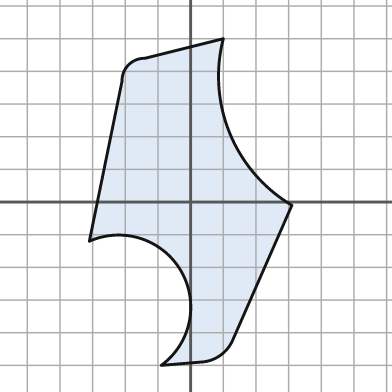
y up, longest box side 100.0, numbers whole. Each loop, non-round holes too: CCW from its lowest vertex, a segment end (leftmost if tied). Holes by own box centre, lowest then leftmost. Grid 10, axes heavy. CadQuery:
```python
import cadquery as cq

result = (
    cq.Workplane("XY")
    .moveTo(-9.0, -50.0)
    .lineTo(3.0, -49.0)
    .threePointArc((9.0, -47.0), (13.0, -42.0))
    .lineTo(31.0, -1.0)
    .threePointArc((12.0, 21.0), (10.0, 50.0))
    .lineTo(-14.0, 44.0)
    .threePointArc((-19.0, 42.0), (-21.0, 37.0))
    .lineTo(-31.0, -12.0)
    .threePointArc((-3.0, -21.0), (-9.0, -50.0))
    .close()
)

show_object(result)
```